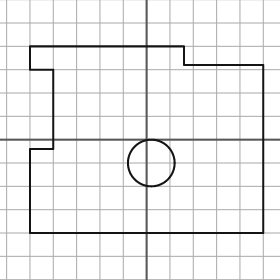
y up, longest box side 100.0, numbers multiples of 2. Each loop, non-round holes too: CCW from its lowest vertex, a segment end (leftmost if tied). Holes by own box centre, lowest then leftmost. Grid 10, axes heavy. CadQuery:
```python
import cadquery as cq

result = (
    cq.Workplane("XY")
    .moveTo(-50.0, -40.0)
    .lineTo(50.0, -40.0)
    .lineTo(50.0, 32.0)
    .lineTo(16.0, 32.0)
    .lineTo(16.0, 40.0)
    .lineTo(-50.0, 40.0)
    .lineTo(-50.0, 30.0)
    .lineTo(-40.0, 30.0)
    .lineTo(-40.0, -4.0)
    .lineTo(-50.0, -4.0)
    .close()
    .moveTo(2.0, -10.0)
    .circle(10.0)
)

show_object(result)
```